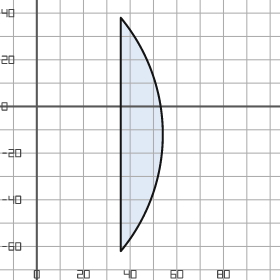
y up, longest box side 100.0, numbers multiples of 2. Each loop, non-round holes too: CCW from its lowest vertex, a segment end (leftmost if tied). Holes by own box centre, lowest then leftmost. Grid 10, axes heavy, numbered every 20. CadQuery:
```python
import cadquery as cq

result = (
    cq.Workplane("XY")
    .moveTo(36.0, -62.0)
    .threePointArc((54.0, -12.0), (36.0, 38.0))
    .close()
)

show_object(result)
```